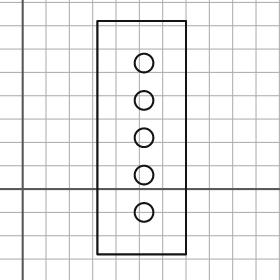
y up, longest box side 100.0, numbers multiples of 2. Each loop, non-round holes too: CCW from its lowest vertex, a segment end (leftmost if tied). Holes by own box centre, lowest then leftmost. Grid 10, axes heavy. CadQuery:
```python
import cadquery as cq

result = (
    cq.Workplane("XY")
    .moveTo(32.0, -28.0)
    .lineTo(70.0, -28.0)
    .lineTo(70.0, 72.0)
    .lineTo(32.0, 72.0)
    .close()
    .moveTo(52.0, -10.0)
    .circle(4.0)
    .moveTo(52.0, 6.0)
    .circle(4.0)
    .moveTo(52.0, 22.0)
    .circle(4.0)
    .moveTo(52.0, 38.0)
    .circle(4.0)
    .moveTo(52.0, 54.0)
    .circle(4.0)
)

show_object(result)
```